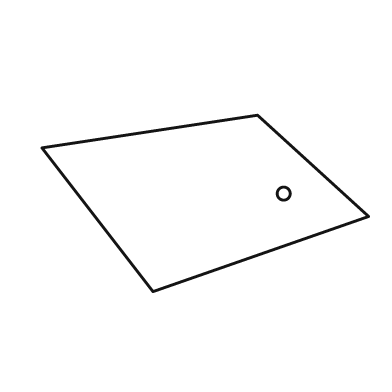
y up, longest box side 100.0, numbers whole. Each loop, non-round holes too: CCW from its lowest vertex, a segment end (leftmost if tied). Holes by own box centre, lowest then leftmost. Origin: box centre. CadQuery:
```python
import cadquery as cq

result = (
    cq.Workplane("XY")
    .moveTo(-16.0, -27.0)
    .lineTo(50.0, -4.0)
    .lineTo(16.0, 27.0)
    .lineTo(-50.0, 17.0)
    .close()
    .moveTo(24.0, 3.0)
    .circle(2.0)
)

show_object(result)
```